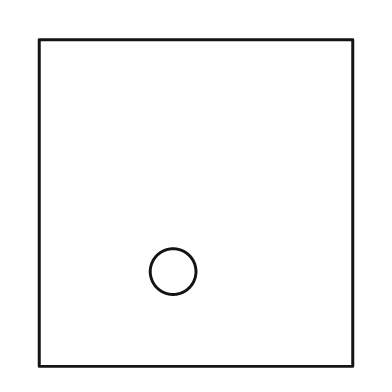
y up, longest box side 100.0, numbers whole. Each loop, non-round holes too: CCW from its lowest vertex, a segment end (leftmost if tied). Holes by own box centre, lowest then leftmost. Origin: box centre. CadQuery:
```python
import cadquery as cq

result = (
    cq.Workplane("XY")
    .moveTo(-48.0, -50.0)
    .lineTo(48.0, -50.0)
    .lineTo(48.0, 50.0)
    .lineTo(-48.0, 50.0)
    .close()
    .moveTo(-7.0, -21.0)
    .circle(7.0)
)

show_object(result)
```